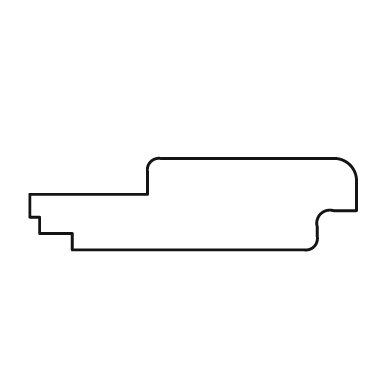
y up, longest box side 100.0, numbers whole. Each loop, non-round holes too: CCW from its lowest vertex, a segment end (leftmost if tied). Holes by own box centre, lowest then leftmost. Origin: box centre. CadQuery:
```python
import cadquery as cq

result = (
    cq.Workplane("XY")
    .moveTo(-37.0, -14.0)
    .lineTo(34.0, -14.0)
    .threePointArc((37.0, -13.0), (38.0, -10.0))
    .lineTo(38.0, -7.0)
    .threePointArc((39.0, -3.0), (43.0, -2.0))
    .lineTo(50.0, -2.0)
    .lineTo(50.0, 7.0)
    .threePointArc((48.0, 12.0), (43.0, 14.0))
    .lineTo(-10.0, 14.0)
    .threePointArc((-13.0, 13.0), (-14.0, 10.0))
    .lineTo(-14.0, 3.0)
    .lineTo(-50.0, 3.0)
    .lineTo(-50.0, -4.0)
    .lineTo(-47.0, -4.0)
    .lineTo(-47.0, -9.0)
    .lineTo(-37.0, -9.0)
    .close()
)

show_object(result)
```